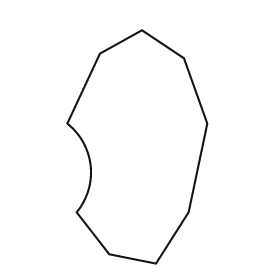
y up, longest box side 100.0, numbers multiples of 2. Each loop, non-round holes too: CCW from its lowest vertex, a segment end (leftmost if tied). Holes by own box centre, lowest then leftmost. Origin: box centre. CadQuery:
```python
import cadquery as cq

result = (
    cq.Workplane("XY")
    .moveTo(8.0, -50.0)
    .lineTo(22.0, -28.0)
    .lineTo(30.0, 10.0)
    .lineTo(20.0, 38.0)
    .lineTo(2.0, 50.0)
    .lineTo(-16.0, 40.0)
    .lineTo(-30.0, 10.0)
    .threePointArc((-20.0, -8.0), (-26.0, -28.0))
    .lineTo(-12.0, -46.0)
    .close()
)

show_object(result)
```